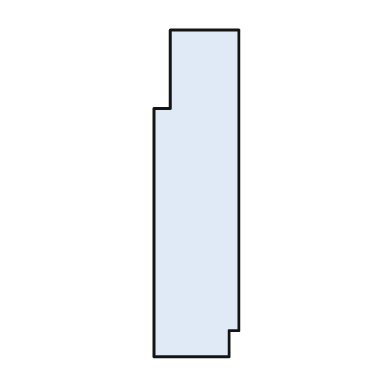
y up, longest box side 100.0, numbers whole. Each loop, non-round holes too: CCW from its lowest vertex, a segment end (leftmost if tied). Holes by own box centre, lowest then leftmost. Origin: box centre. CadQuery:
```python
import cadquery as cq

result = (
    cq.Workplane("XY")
    .moveTo(-13.0, -50.0)
    .lineTo(10.0, -50.0)
    .lineTo(10.0, -42.0)
    .lineTo(13.0, -42.0)
    .lineTo(13.0, 50.0)
    .lineTo(-8.0, 50.0)
    .lineTo(-8.0, 26.0)
    .lineTo(-13.0, 26.0)
    .close()
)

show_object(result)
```